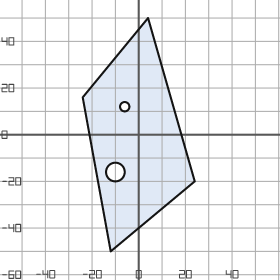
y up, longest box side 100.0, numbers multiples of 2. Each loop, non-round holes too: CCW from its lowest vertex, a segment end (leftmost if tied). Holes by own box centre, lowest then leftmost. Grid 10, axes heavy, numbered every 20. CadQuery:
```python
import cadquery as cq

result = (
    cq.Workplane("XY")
    .moveTo(-12.0, -50.0)
    .lineTo(24.0, -20.0)
    .lineTo(4.0, 50.0)
    .lineTo(-24.0, 16.0)
    .close()
    .moveTo(-10.0, -16.0)
    .circle(4.0)
    .moveTo(-6.0, 12.0)
    .circle(2.0)
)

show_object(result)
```